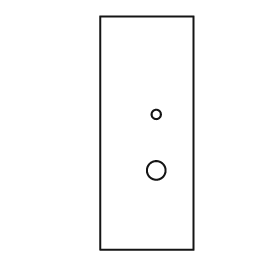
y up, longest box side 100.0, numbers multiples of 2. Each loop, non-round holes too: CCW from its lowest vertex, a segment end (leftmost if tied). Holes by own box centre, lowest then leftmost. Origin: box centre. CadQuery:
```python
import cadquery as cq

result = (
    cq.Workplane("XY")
    .moveTo(-20.0, -50.0)
    .lineTo(20.0, -50.0)
    .lineTo(20.0, 50.0)
    .lineTo(-20.0, 50.0)
    .close()
    .moveTo(4.0, -16.0)
    .circle(4.0)
    .moveTo(4.0, 8.0)
    .circle(2.0)
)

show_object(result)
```